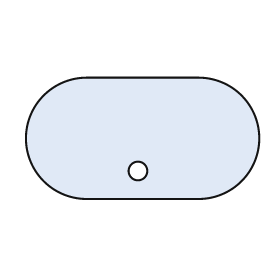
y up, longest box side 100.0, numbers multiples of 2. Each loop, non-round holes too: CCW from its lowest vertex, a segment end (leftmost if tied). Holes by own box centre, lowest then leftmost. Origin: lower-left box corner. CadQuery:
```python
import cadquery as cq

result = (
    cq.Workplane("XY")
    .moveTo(26.0, 0.0)
    .lineTo(74.0, 0.0)
    .threePointArc((100.0, 26.0), (74.0, 52.0))
    .lineTo(26.0, 52.0)
    .threePointArc((0.0, 26.0), (26.0, 0.0))
    .close()
    .moveTo(48.0, 12.0)
    .circle(4.0)
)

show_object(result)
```